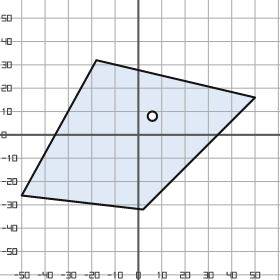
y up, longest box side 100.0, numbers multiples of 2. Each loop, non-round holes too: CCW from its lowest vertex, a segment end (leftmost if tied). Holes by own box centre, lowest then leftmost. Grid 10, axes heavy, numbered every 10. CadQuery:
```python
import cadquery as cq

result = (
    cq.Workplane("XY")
    .moveTo(2.0, -32.0)
    .lineTo(50.0, 16.0)
    .lineTo(-18.0, 32.0)
    .lineTo(-50.0, -26.0)
    .close()
    .moveTo(6.0, 8.0)
    .circle(2.0)
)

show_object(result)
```